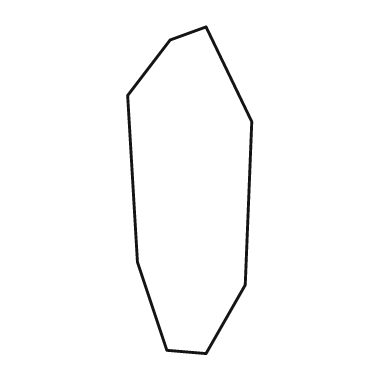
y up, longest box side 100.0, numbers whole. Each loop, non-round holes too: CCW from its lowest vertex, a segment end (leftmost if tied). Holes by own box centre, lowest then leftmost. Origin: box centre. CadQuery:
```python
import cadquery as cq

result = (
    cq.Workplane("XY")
    .moveTo(5.0, -50.0)
    .lineTo(17.0, -29.0)
    .lineTo(19.0, 21.0)
    .lineTo(5.0, 50.0)
    .lineTo(-6.0, 46.0)
    .lineTo(-19.0, 29.0)
    .lineTo(-16.0, -22.0)
    .lineTo(-7.0, -49.0)
    .close()
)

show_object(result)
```